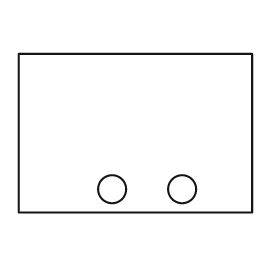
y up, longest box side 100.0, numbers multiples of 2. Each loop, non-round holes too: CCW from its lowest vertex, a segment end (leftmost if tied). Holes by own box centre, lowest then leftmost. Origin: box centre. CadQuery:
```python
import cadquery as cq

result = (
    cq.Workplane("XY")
    .moveTo(-50.0, -34.0)
    .lineTo(50.0, -34.0)
    .lineTo(50.0, 34.0)
    .lineTo(-50.0, 34.0)
    .close()
    .moveTo(-10.0, -24.0)
    .circle(6.0)
    .moveTo(20.0, -24.0)
    .circle(6.0)
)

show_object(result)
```